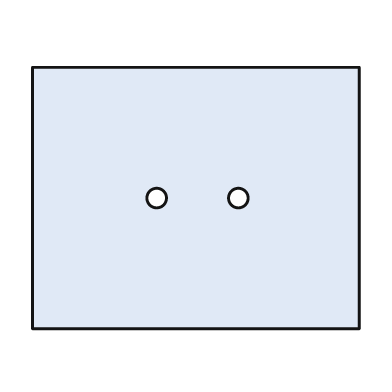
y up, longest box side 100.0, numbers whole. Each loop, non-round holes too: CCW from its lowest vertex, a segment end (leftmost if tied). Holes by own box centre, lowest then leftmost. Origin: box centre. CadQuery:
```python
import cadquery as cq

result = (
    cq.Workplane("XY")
    .moveTo(-50.0, -40.0)
    .lineTo(50.0, -40.0)
    .lineTo(50.0, 40.0)
    .lineTo(-50.0, 40.0)
    .close()
    .moveTo(-12.0, 0.0)
    .circle(3.0)
    .moveTo(13.0, 0.0)
    .circle(3.0)
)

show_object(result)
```